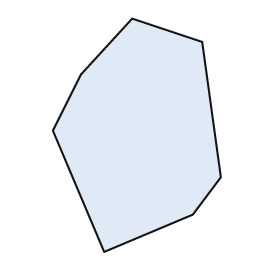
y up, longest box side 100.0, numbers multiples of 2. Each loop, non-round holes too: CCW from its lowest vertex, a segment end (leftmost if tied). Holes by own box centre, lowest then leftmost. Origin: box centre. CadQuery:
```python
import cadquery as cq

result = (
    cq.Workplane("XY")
    .moveTo(-14.0, -50.0)
    .lineTo(24.0, -34.0)
    .lineTo(36.0, -18.0)
    .lineTo(28.0, 40.0)
    .lineTo(-2.0, 50.0)
    .lineTo(-24.0, 26.0)
    .lineTo(-36.0, 2.0)
    .close()
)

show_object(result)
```